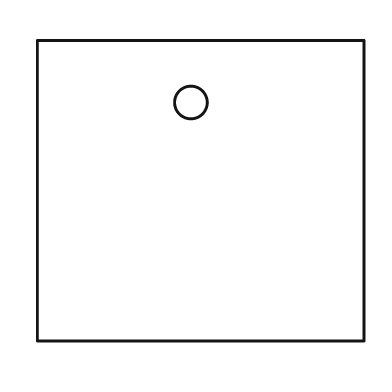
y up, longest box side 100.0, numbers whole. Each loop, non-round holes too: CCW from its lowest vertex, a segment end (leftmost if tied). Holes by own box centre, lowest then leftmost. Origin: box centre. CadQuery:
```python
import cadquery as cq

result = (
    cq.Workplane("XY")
    .moveTo(-50.0, -46.0)
    .lineTo(50.0, -46.0)
    .lineTo(50.0, 46.0)
    .lineTo(-50.0, 46.0)
    .close()
    .moveTo(-3.0, 27.0)
    .circle(5.0)
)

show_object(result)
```